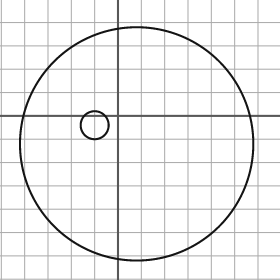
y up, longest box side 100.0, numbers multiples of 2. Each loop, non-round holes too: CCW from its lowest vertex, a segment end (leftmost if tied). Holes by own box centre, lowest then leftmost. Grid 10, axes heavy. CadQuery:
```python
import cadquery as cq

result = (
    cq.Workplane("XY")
    .moveTo(8.0, -12.0)
    .circle(50.0)
    .moveTo(-10.0, -4.0)
    .circle(6.0)
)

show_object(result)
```